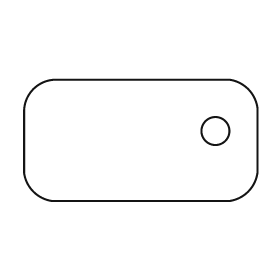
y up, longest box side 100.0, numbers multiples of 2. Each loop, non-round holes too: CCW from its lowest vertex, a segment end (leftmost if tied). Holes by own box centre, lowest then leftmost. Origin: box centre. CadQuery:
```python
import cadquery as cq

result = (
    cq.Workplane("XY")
    .moveTo(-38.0, -26.0)
    .lineTo(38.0, -26.0)
    .threePointArc((46.0, -22.0), (50.0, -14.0))
    .lineTo(50.0, 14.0)
    .threePointArc((46.0, 22.0), (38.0, 26.0))
    .lineTo(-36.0, 26.0)
    .threePointArc((-46.0, 22.0), (-50.0, 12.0))
    .lineTo(-50.0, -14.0)
    .threePointArc((-46.0, -22.0), (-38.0, -26.0))
    .close()
    .moveTo(32.0, 4.0)
    .circle(6.0)
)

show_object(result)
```